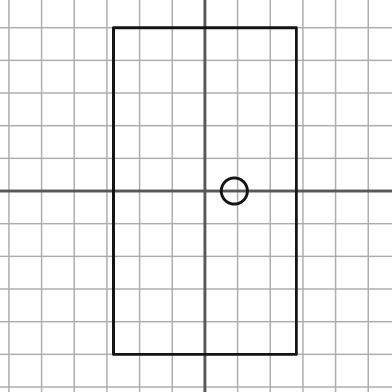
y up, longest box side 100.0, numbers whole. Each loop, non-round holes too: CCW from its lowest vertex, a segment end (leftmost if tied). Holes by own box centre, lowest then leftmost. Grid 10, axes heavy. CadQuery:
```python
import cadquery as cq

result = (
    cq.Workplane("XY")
    .moveTo(-28.0, -50.0)
    .lineTo(28.0, -50.0)
    .lineTo(28.0, 50.0)
    .lineTo(-28.0, 50.0)
    .close()
    .moveTo(9.0, 0.0)
    .circle(4.0)
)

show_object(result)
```